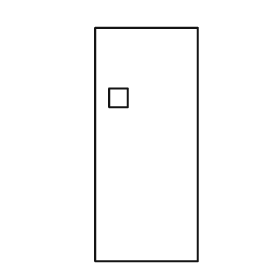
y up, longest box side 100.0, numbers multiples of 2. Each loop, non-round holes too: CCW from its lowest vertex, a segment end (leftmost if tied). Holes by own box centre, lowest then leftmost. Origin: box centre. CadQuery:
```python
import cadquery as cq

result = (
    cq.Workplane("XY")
    .moveTo(-22.0, -50.0)
    .lineTo(22.0, -50.0)
    .lineTo(22.0, 50.0)
    .lineTo(-22.0, 50.0)
    .close()
    .moveTo(-16.0, 16.0)
    .lineTo(-8.0, 16.0)
    .lineTo(-8.0, 24.0)
    .lineTo(-16.0, 24.0)
    .close()
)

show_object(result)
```